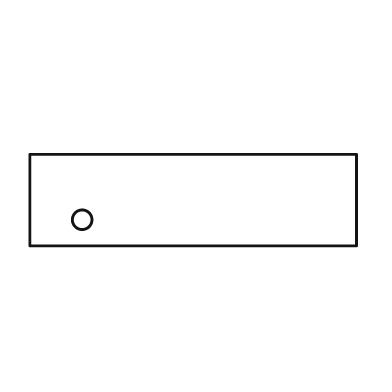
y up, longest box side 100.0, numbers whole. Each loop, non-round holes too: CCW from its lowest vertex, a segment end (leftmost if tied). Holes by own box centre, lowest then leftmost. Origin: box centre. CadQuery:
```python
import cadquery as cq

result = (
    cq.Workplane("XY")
    .moveTo(-50.0, -14.0)
    .lineTo(50.0, -14.0)
    .lineTo(50.0, 14.0)
    .lineTo(-50.0, 14.0)
    .close()
    .moveTo(-34.0, -6.0)
    .circle(3.0)
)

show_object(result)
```